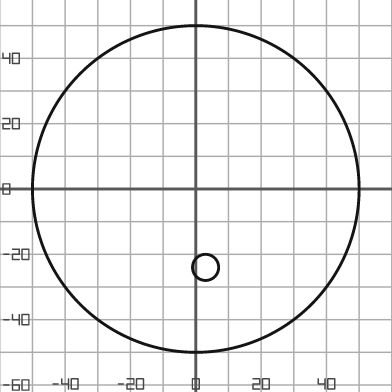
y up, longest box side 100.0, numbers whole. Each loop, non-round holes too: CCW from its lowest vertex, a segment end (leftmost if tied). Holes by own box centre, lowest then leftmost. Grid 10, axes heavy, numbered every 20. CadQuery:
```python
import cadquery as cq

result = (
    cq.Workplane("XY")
    .moveTo(0.0, 0.0)
    .circle(50.0)
    .moveTo(3.0, -24.0)
    .circle(4.0)
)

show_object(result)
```